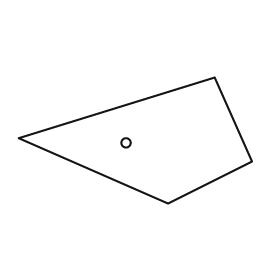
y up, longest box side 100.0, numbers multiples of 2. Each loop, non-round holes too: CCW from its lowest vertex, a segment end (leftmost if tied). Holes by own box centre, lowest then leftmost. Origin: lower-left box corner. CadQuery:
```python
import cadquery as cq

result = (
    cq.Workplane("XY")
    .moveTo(64.0, 0.0)
    .lineTo(100.0, 18.0)
    .lineTo(84.0, 54.0)
    .lineTo(0.0, 28.0)
    .close()
    .moveTo(46.0, 26.0)
    .circle(2.0)
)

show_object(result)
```